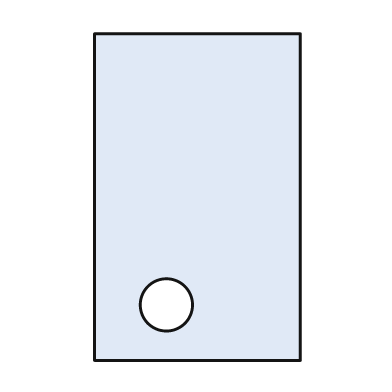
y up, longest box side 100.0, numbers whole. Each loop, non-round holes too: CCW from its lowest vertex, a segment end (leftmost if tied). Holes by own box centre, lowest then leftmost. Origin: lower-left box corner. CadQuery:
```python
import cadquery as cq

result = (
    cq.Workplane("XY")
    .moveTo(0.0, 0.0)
    .lineTo(63.0, 0.0)
    .lineTo(63.0, 100.0)
    .lineTo(0.0, 100.0)
    .close()
    .moveTo(22.0, 17.0)
    .circle(8.0)
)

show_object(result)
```